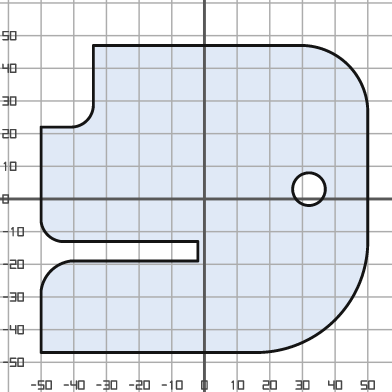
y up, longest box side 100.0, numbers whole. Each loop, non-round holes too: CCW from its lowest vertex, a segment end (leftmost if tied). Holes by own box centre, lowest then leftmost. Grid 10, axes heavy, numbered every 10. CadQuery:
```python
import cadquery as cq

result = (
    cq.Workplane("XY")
    .moveTo(-50.0, -47.0)
    .lineTo(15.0, -47.0)
    .threePointArc((40.0, -37.0), (50.0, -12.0))
    .lineTo(50.0, 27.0)
    .threePointArc((44.0, 41.0), (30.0, 47.0))
    .lineTo(-34.0, 47.0)
    .lineTo(-34.0, 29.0)
    .threePointArc((-36.0, 24.0), (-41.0, 22.0))
    .lineTo(-50.0, 22.0)
    .lineTo(-50.0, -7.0)
    .threePointArc((-48.0, -11.0), (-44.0, -13.0))
    .lineTo(-2.0, -13.0)
    .lineTo(-2.0, -19.0)
    .lineTo(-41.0, -19.0)
    .threePointArc((-47.0, -22.0), (-50.0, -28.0))
    .close()
    .moveTo(32.0, 3.0)
    .circle(5.0)
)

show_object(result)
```